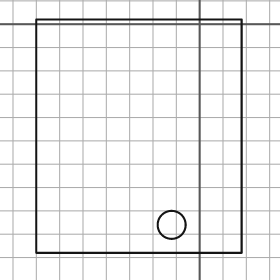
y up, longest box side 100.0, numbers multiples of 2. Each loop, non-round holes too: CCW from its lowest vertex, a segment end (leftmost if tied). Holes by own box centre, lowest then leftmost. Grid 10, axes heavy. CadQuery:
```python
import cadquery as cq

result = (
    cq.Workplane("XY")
    .moveTo(-70.0, -98.0)
    .lineTo(18.0, -98.0)
    .lineTo(18.0, 2.0)
    .lineTo(-70.0, 2.0)
    .close()
    .moveTo(-12.0, -86.0)
    .circle(6.0)
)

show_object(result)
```